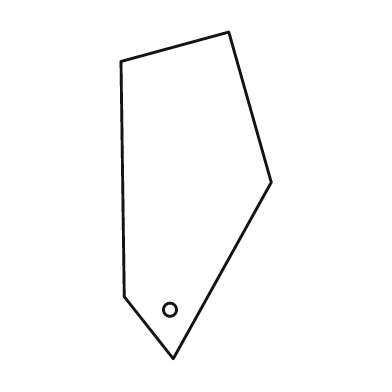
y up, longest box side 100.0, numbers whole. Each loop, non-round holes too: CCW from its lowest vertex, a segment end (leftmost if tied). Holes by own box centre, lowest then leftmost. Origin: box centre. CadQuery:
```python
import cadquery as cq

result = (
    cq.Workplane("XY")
    .moveTo(-7.0, -50.0)
    .lineTo(23.0, 4.0)
    .lineTo(10.0, 50.0)
    .lineTo(-23.0, 41.0)
    .lineTo(-22.0, -31.0)
    .close()
    .moveTo(-8.0, -35.0)
    .circle(2.0)
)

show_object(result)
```